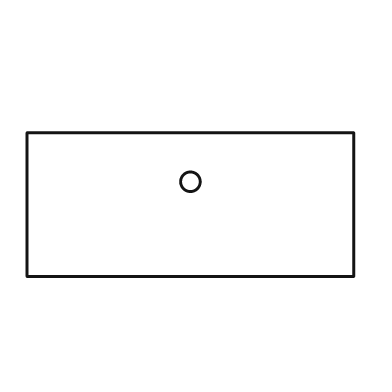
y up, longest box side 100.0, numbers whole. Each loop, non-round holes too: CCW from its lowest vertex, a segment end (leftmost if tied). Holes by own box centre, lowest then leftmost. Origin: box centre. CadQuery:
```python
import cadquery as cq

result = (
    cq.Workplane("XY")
    .moveTo(-50.0, -22.0)
    .lineTo(50.0, -22.0)
    .lineTo(50.0, 22.0)
    .lineTo(-50.0, 22.0)
    .close()
    .moveTo(0.0, 7.0)
    .circle(3.0)
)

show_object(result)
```